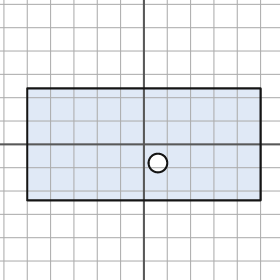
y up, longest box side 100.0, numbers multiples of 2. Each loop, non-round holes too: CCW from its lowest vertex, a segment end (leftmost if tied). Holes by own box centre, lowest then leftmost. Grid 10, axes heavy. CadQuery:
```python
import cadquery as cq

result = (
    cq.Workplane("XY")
    .moveTo(-50.0, -24.0)
    .lineTo(50.0, -24.0)
    .lineTo(50.0, 24.0)
    .lineTo(-50.0, 24.0)
    .close()
    .moveTo(6.0, -8.0)
    .circle(4.0)
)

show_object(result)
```